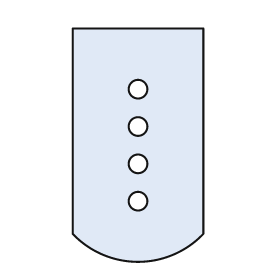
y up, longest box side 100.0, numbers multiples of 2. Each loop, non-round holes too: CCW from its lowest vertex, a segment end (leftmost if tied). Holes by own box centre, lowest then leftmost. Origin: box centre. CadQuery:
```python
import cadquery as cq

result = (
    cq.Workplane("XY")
    .moveTo(-28.0, -38.0)
    .threePointArc((0.0, -50.0), (28.0, -38.0))
    .lineTo(28.0, 50.0)
    .lineTo(-28.0, 50.0)
    .close()
    .moveTo(0.0, -24.0)
    .circle(4.0)
    .moveTo(0.0, -8.0)
    .circle(4.0)
    .moveTo(0.0, 8.0)
    .circle(4.0)
    .moveTo(0.0, 24.0)
    .circle(4.0)
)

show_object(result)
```